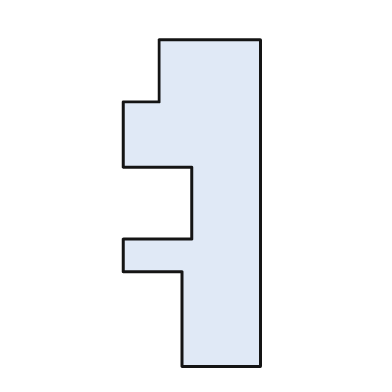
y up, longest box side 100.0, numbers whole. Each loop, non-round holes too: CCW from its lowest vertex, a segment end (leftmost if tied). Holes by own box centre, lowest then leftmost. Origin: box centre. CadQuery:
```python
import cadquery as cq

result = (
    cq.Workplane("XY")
    .moveTo(-3.0, -50.0)
    .lineTo(21.0, -50.0)
    .lineTo(21.0, 50.0)
    .lineTo(-10.0, 50.0)
    .lineTo(-10.0, 31.0)
    .lineTo(-21.0, 31.0)
    .lineTo(-21.0, 11.0)
    .lineTo(0.0, 11.0)
    .lineTo(0.0, -11.0)
    .lineTo(-21.0, -11.0)
    .lineTo(-21.0, -21.0)
    .lineTo(-3.0, -21.0)
    .close()
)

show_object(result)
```